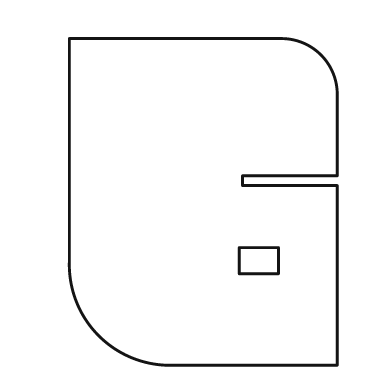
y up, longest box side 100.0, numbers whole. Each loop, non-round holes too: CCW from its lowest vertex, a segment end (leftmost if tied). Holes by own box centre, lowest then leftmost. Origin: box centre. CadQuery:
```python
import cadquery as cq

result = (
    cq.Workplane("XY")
    .moveTo(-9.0, -50.0)
    .lineTo(41.0, -50.0)
    .lineTo(41.0, 5.0)
    .lineTo(12.0, 5.0)
    .lineTo(12.0, 8.0)
    .lineTo(41.0, 8.0)
    .lineTo(41.0, 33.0)
    .threePointArc((36.0, 45.0), (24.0, 50.0))
    .lineTo(-41.0, 50.0)
    .lineTo(-41.0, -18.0)
    .threePointArc((-32.0, -41.0), (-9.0, -50.0))
    .close()
    .moveTo(11.0, -22.0)
    .lineTo(23.0, -22.0)
    .lineTo(23.0, -14.0)
    .lineTo(11.0, -14.0)
    .close()
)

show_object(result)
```